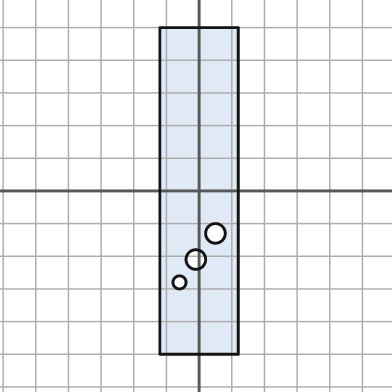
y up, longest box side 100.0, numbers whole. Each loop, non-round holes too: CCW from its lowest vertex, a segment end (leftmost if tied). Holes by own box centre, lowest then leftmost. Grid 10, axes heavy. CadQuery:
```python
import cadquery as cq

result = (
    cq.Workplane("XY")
    .moveTo(-12.0, -50.0)
    .lineTo(12.0, -50.0)
    .lineTo(12.0, 50.0)
    .lineTo(-12.0, 50.0)
    .close()
    .moveTo(-6.0, -28.0)
    .circle(2.0)
    .moveTo(-1.0, -21.0)
    .circle(3.0)
    .moveTo(5.0, -13.0)
    .circle(3.0)
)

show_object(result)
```